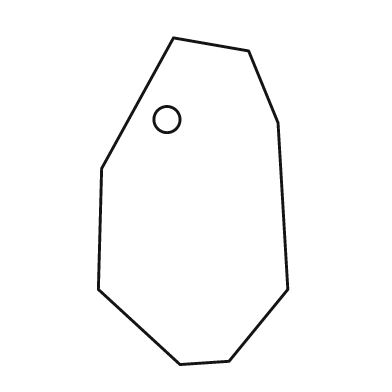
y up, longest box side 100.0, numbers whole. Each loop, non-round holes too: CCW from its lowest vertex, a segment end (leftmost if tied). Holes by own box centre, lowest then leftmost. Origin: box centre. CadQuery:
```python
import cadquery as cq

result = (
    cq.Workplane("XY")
    .moveTo(-4.0, -50.0)
    .lineTo(11.0, -49.0)
    .lineTo(29.0, -27.0)
    .lineTo(26.0, 24.0)
    .lineTo(17.0, 46.0)
    .lineTo(-6.0, 50.0)
    .lineTo(-28.0, 10.0)
    .lineTo(-29.0, -27.0)
    .close()
    .moveTo(-8.0, 25.0)
    .circle(4.0)
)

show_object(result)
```